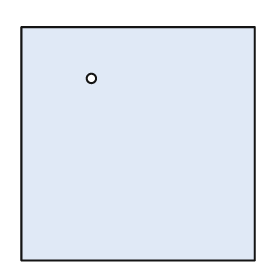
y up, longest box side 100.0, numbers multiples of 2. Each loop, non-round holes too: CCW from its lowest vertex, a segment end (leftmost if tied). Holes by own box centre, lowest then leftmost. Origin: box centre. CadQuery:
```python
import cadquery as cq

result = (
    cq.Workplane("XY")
    .moveTo(-50.0, -50.0)
    .lineTo(50.0, -50.0)
    .lineTo(50.0, 50.0)
    .lineTo(-50.0, 50.0)
    .close()
    .moveTo(-20.0, 28.0)
    .circle(2.0)
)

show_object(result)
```